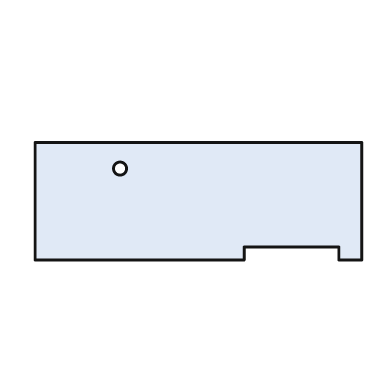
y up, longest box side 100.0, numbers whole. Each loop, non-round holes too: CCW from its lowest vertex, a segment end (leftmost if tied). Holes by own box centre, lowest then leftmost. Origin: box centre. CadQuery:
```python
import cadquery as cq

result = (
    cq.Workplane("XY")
    .moveTo(-50.0, -18.0)
    .lineTo(14.0, -18.0)
    .lineTo(14.0, -14.0)
    .lineTo(43.0, -14.0)
    .lineTo(43.0, -18.0)
    .lineTo(50.0, -18.0)
    .lineTo(50.0, 18.0)
    .lineTo(-50.0, 18.0)
    .close()
    .moveTo(-24.0, 10.0)
    .circle(2.0)
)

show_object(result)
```